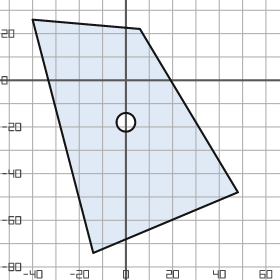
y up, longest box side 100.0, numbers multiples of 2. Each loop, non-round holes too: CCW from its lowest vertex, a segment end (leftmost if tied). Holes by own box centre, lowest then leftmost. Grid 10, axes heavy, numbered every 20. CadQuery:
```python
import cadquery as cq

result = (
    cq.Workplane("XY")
    .moveTo(-14.0, -74.0)
    .lineTo(48.0, -48.0)
    .lineTo(6.0, 22.0)
    .lineTo(-40.0, 26.0)
    .close()
    .moveTo(0.0, -18.0)
    .circle(4.0)
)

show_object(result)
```